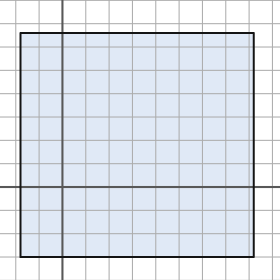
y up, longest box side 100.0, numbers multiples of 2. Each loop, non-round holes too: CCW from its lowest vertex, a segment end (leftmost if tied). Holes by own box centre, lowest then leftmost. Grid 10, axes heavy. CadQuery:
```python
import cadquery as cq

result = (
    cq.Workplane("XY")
    .moveTo(-18.0, -30.0)
    .lineTo(82.0, -30.0)
    .lineTo(82.0, 66.0)
    .lineTo(-18.0, 66.0)
    .close()
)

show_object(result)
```